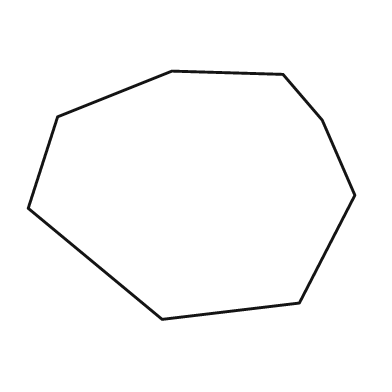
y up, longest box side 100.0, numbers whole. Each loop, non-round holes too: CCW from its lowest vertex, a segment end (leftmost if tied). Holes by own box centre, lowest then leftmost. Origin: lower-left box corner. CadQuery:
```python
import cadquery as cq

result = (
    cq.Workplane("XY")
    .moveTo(41.0, 0.0)
    .lineTo(83.0, 5.0)
    .lineTo(100.0, 38.0)
    .lineTo(90.0, 61.0)
    .lineTo(78.0, 75.0)
    .lineTo(44.0, 76.0)
    .lineTo(9.0, 62.0)
    .lineTo(0.0, 34.0)
    .close()
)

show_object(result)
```